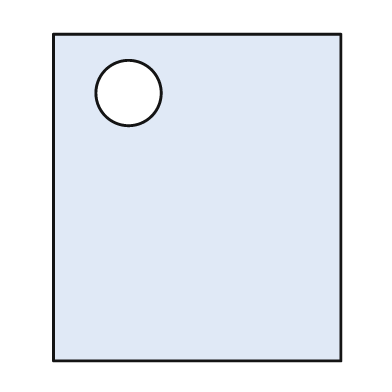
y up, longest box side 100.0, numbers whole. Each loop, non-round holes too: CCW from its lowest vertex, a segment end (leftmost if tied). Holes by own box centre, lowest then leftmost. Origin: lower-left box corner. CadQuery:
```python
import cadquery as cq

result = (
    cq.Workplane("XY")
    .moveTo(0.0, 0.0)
    .lineTo(88.0, 0.0)
    .lineTo(88.0, 100.0)
    .lineTo(0.0, 100.0)
    .close()
    .moveTo(23.0, 82.0)
    .circle(10.0)
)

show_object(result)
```